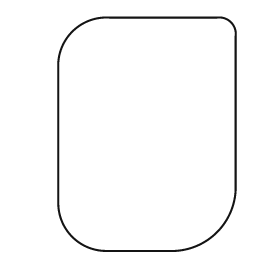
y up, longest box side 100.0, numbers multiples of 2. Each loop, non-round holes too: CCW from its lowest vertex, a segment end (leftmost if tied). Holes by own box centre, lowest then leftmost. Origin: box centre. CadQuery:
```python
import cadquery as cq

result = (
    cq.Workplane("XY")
    .moveTo(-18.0, -50.0)
    .lineTo(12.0, -50.0)
    .threePointArc((30.0, -42.0), (38.0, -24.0))
    .lineTo(38.0, 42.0)
    .threePointArc((36.0, 48.0), (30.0, 50.0))
    .lineTo(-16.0, 50.0)
    .threePointArc((-32.0, 44.0), (-38.0, 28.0))
    .lineTo(-38.0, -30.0)
    .threePointArc((-32.0, -44.0), (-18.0, -50.0))
    .close()
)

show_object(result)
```